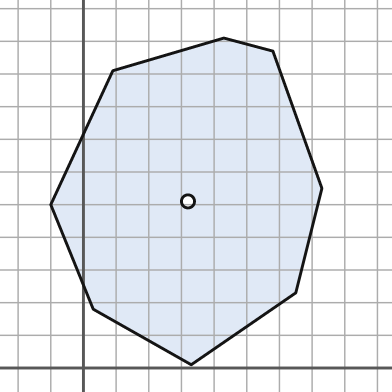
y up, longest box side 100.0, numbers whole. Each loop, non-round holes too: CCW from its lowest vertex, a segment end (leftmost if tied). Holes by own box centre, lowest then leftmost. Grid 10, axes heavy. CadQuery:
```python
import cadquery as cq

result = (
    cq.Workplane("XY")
    .moveTo(33.0, 1.0)
    .lineTo(65.0, 23.0)
    .lineTo(73.0, 55.0)
    .lineTo(58.0, 97.0)
    .lineTo(43.0, 101.0)
    .lineTo(9.0, 91.0)
    .lineTo(-10.0, 50.0)
    .lineTo(3.0, 18.0)
    .close()
    .moveTo(32.0, 51.0)
    .circle(2.0)
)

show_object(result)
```